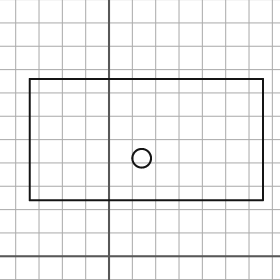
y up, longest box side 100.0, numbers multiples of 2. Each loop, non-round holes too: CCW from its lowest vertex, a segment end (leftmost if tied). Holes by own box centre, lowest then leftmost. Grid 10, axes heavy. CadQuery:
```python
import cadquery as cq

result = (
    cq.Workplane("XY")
    .moveTo(-34.0, 24.0)
    .lineTo(66.0, 24.0)
    .lineTo(66.0, 76.0)
    .lineTo(-34.0, 76.0)
    .close()
    .moveTo(14.0, 42.0)
    .circle(4.0)
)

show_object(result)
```